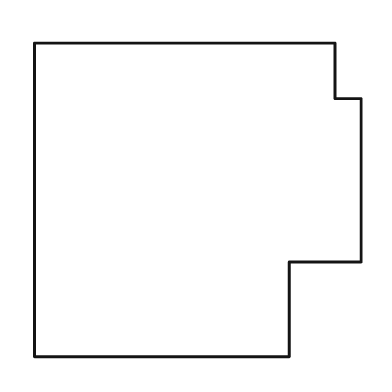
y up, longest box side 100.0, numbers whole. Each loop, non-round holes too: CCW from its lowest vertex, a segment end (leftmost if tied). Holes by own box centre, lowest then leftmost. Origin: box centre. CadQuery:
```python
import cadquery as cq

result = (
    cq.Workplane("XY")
    .moveTo(-50.0, -48.0)
    .lineTo(28.0, -48.0)
    .lineTo(28.0, -19.0)
    .lineTo(50.0, -19.0)
    .lineTo(50.0, 31.0)
    .lineTo(42.0, 31.0)
    .lineTo(42.0, 48.0)
    .lineTo(-50.0, 48.0)
    .close()
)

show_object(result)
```